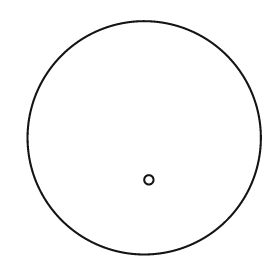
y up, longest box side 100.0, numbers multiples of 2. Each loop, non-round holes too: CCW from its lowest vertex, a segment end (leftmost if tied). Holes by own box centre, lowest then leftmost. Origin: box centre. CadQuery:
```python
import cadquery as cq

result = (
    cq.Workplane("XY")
    .moveTo(0.0, 0.0)
    .circle(50.0)
    .moveTo(2.0, -18.0)
    .circle(2.0)
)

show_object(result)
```